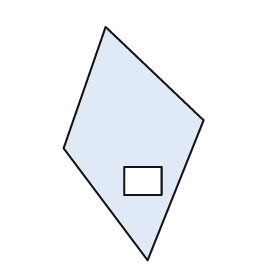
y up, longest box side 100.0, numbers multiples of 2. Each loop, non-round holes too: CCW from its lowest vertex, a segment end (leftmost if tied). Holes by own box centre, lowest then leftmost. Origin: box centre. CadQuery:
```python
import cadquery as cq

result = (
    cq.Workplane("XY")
    .moveTo(6.0, -50.0)
    .lineTo(30.0, 10.0)
    .lineTo(-12.0, 50.0)
    .lineTo(-30.0, -2.0)
    .close()
    .moveTo(-4.0, -22.0)
    .lineTo(12.0, -22.0)
    .lineTo(12.0, -10.0)
    .lineTo(-4.0, -10.0)
    .close()
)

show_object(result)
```